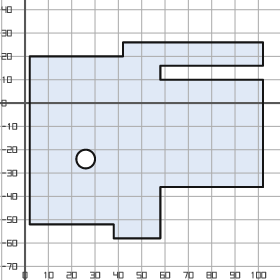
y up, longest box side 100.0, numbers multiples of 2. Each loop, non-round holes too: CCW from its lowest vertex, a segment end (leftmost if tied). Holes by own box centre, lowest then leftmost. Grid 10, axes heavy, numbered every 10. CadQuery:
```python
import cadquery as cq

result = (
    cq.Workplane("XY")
    .moveTo(38.0, -58.0)
    .lineTo(58.0, -58.0)
    .lineTo(58.0, -36.0)
    .lineTo(102.0, -36.0)
    .lineTo(102.0, 10.0)
    .lineTo(58.0, 10.0)
    .lineTo(58.0, 16.0)
    .lineTo(102.0, 16.0)
    .lineTo(102.0, 26.0)
    .lineTo(42.0, 26.0)
    .lineTo(42.0, 20.0)
    .lineTo(2.0, 20.0)
    .lineTo(2.0, -52.0)
    .lineTo(38.0, -52.0)
    .close()
    .moveTo(26.0, -24.0)
    .circle(4.0)
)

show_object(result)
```